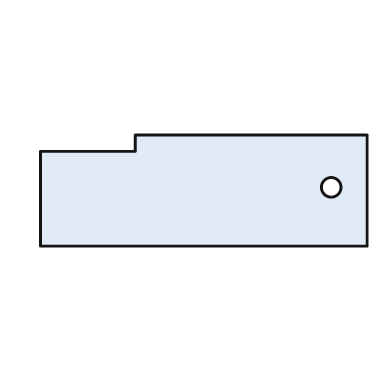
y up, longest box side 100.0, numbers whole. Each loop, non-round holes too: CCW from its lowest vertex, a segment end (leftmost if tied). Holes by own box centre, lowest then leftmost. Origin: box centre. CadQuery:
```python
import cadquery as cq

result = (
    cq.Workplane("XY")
    .moveTo(-50.0, -17.0)
    .lineTo(50.0, -17.0)
    .lineTo(50.0, 17.0)
    .lineTo(-21.0, 17.0)
    .lineTo(-21.0, 12.0)
    .lineTo(-50.0, 12.0)
    .close()
    .moveTo(39.0, 1.0)
    .circle(3.0)
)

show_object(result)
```